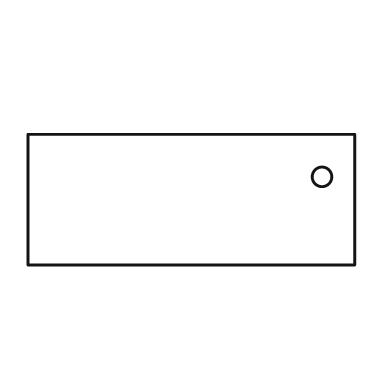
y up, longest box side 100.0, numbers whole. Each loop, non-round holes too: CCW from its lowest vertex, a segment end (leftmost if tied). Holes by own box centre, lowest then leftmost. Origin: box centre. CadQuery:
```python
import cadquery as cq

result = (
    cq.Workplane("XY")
    .moveTo(-50.0, -20.0)
    .lineTo(50.0, -20.0)
    .lineTo(50.0, 20.0)
    .lineTo(-50.0, 20.0)
    .close()
    .moveTo(40.0, 7.0)
    .circle(3.0)
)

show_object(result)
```